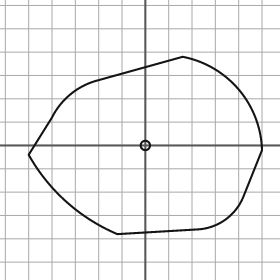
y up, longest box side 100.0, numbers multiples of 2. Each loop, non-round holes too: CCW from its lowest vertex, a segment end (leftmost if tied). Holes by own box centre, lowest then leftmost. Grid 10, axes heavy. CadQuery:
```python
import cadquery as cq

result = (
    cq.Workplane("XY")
    .moveTo(-12.0, -38.0)
    .lineTo(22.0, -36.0)
    .threePointArc((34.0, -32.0), (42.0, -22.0))
    .lineTo(50.0, -2.0)
    .threePointArc((40.0, 24.0), (16.0, 38.0))
    .lineTo(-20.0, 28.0)
    .threePointArc((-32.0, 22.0), (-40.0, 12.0))
    .lineTo(-50.0, -4.0)
    .threePointArc((-34.0, -24.0), (-12.0, -38.0))
    .close()
    .moveTo(0.0, 0.0)
    .circle(2.0)
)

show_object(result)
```